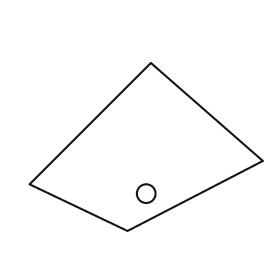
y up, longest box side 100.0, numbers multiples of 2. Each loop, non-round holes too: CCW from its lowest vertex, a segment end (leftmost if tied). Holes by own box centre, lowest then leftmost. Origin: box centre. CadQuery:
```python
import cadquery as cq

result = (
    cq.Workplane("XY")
    .moveTo(-8.0, -36.0)
    .lineTo(50.0, -6.0)
    .lineTo(2.0, 36.0)
    .lineTo(-50.0, -16.0)
    .close()
    .moveTo(0.0, -20.0)
    .circle(4.0)
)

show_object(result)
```